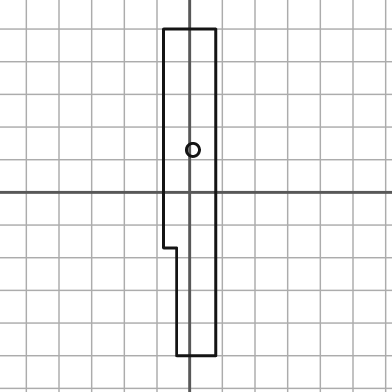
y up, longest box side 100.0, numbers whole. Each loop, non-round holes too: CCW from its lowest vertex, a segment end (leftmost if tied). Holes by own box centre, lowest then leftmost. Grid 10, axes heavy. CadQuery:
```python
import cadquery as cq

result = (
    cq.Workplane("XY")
    .moveTo(-4.0, -50.0)
    .lineTo(8.0, -50.0)
    .lineTo(8.0, 50.0)
    .lineTo(-8.0, 50.0)
    .lineTo(-8.0, -17.0)
    .lineTo(-4.0, -17.0)
    .close()
    .moveTo(1.0, 13.0)
    .circle(2.0)
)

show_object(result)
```